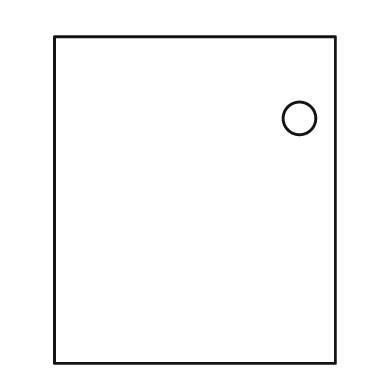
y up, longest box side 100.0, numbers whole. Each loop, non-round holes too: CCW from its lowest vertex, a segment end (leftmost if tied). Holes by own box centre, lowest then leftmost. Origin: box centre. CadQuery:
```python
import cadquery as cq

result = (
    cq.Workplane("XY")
    .moveTo(-43.0, -50.0)
    .lineTo(43.0, -50.0)
    .lineTo(43.0, 50.0)
    .lineTo(-43.0, 50.0)
    .close()
    .moveTo(32.0, 25.0)
    .circle(5.0)
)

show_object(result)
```